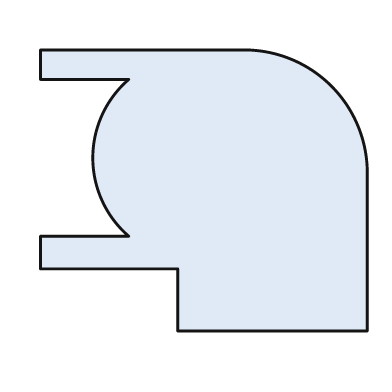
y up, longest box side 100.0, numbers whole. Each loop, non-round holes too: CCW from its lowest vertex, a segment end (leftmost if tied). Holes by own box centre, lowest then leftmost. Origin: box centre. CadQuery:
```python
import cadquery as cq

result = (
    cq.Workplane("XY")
    .moveTo(-8.0, -43.0)
    .lineTo(50.0, -43.0)
    .lineTo(50.0, 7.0)
    .threePointArc((39.0, 32.0), (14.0, 43.0))
    .lineTo(-50.0, 43.0)
    .lineTo(-50.0, 34.0)
    .lineTo(-23.0, 34.0)
    .threePointArc((-34.0, 10.0), (-23.0, -14.0))
    .lineTo(-50.0, -14.0)
    .lineTo(-50.0, -24.0)
    .lineTo(-8.0, -24.0)
    .close()
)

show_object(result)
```